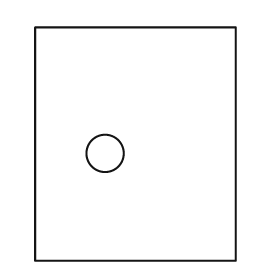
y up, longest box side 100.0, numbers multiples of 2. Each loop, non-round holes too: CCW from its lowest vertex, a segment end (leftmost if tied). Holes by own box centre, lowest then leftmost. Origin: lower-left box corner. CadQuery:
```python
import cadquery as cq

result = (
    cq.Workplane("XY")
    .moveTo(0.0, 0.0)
    .lineTo(86.0, 0.0)
    .lineTo(86.0, 100.0)
    .lineTo(0.0, 100.0)
    .close()
    .moveTo(30.0, 46.0)
    .circle(8.0)
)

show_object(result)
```